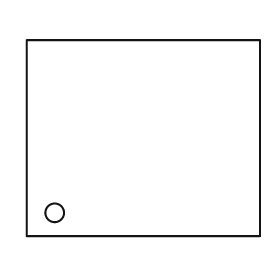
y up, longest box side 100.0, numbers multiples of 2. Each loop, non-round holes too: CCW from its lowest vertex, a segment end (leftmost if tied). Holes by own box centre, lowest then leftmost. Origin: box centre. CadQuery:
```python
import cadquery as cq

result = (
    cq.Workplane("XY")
    .moveTo(-50.0, -42.0)
    .lineTo(50.0, -42.0)
    .lineTo(50.0, 42.0)
    .lineTo(-50.0, 42.0)
    .close()
    .moveTo(-38.0, -32.0)
    .circle(4.0)
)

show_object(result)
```